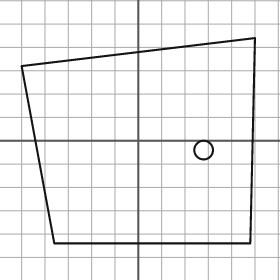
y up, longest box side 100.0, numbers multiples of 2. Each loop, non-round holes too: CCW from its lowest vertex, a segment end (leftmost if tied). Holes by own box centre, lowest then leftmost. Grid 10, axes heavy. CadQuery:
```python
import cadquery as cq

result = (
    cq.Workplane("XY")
    .moveTo(-36.0, -44.0)
    .lineTo(48.0, -44.0)
    .lineTo(50.0, 44.0)
    .lineTo(-50.0, 32.0)
    .close()
    .moveTo(28.0, -4.0)
    .circle(4.0)
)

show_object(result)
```